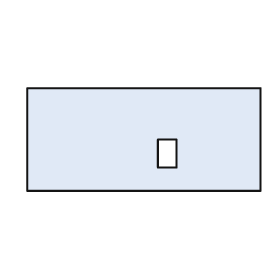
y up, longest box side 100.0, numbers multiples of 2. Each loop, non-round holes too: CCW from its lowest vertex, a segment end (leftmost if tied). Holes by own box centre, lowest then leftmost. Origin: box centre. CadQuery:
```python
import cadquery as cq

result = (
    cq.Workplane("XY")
    .moveTo(-50.0, -22.0)
    .lineTo(50.0, -22.0)
    .lineTo(50.0, 22.0)
    .lineTo(-50.0, 22.0)
    .close()
    .moveTo(6.0, -12.0)
    .lineTo(14.0, -12.0)
    .lineTo(14.0, 0.0)
    .lineTo(6.0, 0.0)
    .close()
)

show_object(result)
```